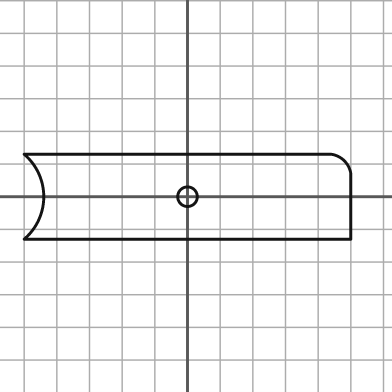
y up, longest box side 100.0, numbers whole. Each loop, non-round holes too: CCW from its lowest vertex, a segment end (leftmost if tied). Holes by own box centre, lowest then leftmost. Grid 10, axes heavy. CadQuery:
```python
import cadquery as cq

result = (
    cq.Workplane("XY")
    .moveTo(-50.0, -13.0)
    .lineTo(50.0, -13.0)
    .lineTo(50.0, 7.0)
    .threePointArc((48.0, 11.0), (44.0, 13.0))
    .lineTo(-50.0, 13.0)
    .threePointArc((-44.0, 0.0), (-50.0, -13.0))
    .close()
    .moveTo(0.0, 0.0)
    .circle(3.0)
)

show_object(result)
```